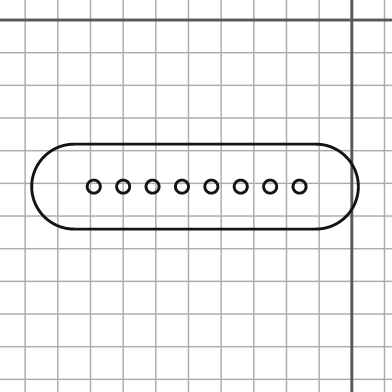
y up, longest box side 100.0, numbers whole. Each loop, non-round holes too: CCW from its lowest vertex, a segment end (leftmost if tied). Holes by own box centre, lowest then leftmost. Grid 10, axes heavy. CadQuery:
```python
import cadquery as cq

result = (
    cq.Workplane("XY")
    .moveTo(-85.0, -64.0)
    .lineTo(-11.0, -64.0)
    .threePointArc((2.0, -51.0), (-11.0, -38.0))
    .lineTo(-85.0, -38.0)
    .threePointArc((-98.0, -51.0), (-85.0, -64.0))
    .close()
    .moveTo(-79.0, -51.0)
    .circle(2.0)
    .moveTo(-70.0, -51.0)
    .circle(2.0)
    .moveTo(-61.0, -51.0)
    .circle(2.0)
    .moveTo(-52.0, -51.0)
    .circle(2.0)
    .moveTo(-43.0, -51.0)
    .circle(2.0)
    .moveTo(-34.0, -51.0)
    .circle(2.0)
    .moveTo(-25.0, -51.0)
    .circle(2.0)
    .moveTo(-16.0, -51.0)
    .circle(2.0)
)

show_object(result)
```